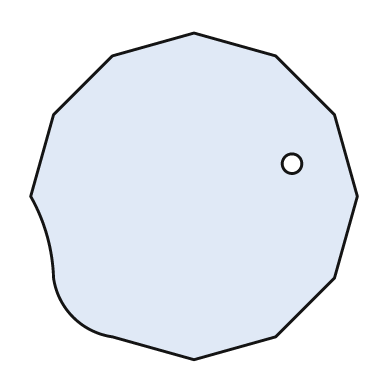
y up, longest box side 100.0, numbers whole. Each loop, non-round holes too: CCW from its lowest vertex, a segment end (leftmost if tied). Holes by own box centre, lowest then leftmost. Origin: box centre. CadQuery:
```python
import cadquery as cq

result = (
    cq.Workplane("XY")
    .moveTo(0.0, -50.0)
    .lineTo(25.0, -43.0)
    .lineTo(43.0, -25.0)
    .lineTo(50.0, 0.0)
    .lineTo(43.0, 25.0)
    .lineTo(25.0, 43.0)
    .lineTo(0.0, 50.0)
    .lineTo(-25.0, 43.0)
    .lineTo(-43.0, 25.0)
    .lineTo(-50.0, 0.0)
    .threePointArc((-45.0, -12.0), (-43.0, -25.0))
    .threePointArc((-37.0, -37.0), (-25.0, -43.0))
    .close()
    .moveTo(30.0, 10.0)
    .circle(3.0)
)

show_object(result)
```